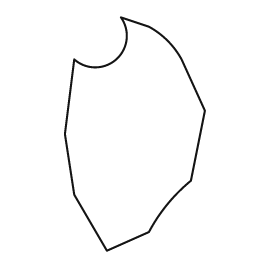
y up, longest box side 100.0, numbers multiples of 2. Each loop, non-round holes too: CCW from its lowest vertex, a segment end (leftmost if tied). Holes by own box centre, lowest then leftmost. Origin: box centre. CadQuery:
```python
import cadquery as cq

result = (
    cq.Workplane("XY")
    .moveTo(-12.0, -50.0)
    .lineTo(6.0, -42.0)
    .threePointArc((14.0, -30.0), (24.0, -20.0))
    .lineTo(30.0, 10.0)
    .lineTo(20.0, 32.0)
    .threePointArc((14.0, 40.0), (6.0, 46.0))
    .lineTo(-6.0, 50.0)
    .threePointArc((-8.0, 32.0), (-26.0, 32.0))
    .lineTo(-30.0, 0.0)
    .lineTo(-26.0, -26.0)
    .close()
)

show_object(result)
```